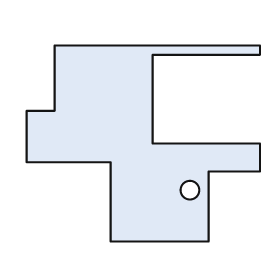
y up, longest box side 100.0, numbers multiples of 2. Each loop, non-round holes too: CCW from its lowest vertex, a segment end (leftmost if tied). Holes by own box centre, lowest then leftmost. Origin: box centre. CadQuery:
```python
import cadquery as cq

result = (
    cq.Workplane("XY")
    .moveTo(-14.0, -42.0)
    .lineTo(28.0, -42.0)
    .lineTo(28.0, -12.0)
    .lineTo(50.0, -12.0)
    .lineTo(50.0, 0.0)
    .lineTo(4.0, 0.0)
    .lineTo(4.0, 38.0)
    .lineTo(50.0, 38.0)
    .lineTo(50.0, 42.0)
    .lineTo(-38.0, 42.0)
    .lineTo(-38.0, 14.0)
    .lineTo(-50.0, 14.0)
    .lineTo(-50.0, -8.0)
    .lineTo(-14.0, -8.0)
    .close()
    .moveTo(20.0, -20.0)
    .circle(4.0)
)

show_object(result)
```